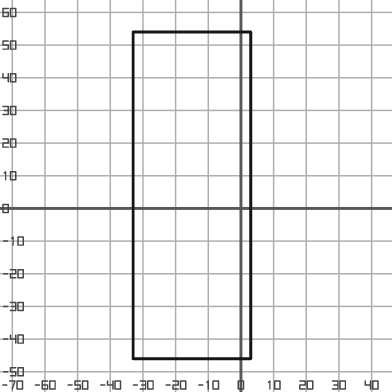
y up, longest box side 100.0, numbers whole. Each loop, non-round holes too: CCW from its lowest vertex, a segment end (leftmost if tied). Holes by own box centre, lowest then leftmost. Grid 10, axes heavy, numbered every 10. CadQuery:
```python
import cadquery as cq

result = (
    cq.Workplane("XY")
    .moveTo(-33.0, -46.0)
    .lineTo(3.0, -46.0)
    .lineTo(3.0, 54.0)
    .lineTo(-33.0, 54.0)
    .close()
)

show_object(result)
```